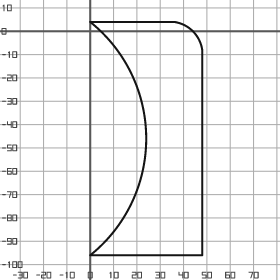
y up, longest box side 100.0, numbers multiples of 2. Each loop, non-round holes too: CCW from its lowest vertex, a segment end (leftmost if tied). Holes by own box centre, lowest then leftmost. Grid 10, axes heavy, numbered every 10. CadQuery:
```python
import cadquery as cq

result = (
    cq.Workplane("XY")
    .moveTo(0.0, -96.0)
    .lineTo(48.0, -96.0)
    .lineTo(48.0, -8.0)
    .threePointArc((44.0, 0.0), (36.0, 4.0))
    .lineTo(0.0, 4.0)
    .threePointArc((24.0, -46.0), (0.0, -96.0))
    .close()
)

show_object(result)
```